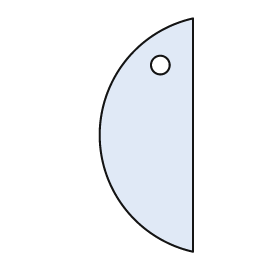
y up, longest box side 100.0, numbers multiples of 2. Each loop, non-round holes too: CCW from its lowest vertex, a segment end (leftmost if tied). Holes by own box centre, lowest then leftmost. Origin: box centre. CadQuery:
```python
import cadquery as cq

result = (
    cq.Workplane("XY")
    .moveTo(20.0, -50.0)
    .lineTo(20.0, 50.0)
    .threePointArc((-20.0, 0.0), (20.0, -50.0))
    .close()
    .moveTo(6.0, 30.0)
    .circle(4.0)
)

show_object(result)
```